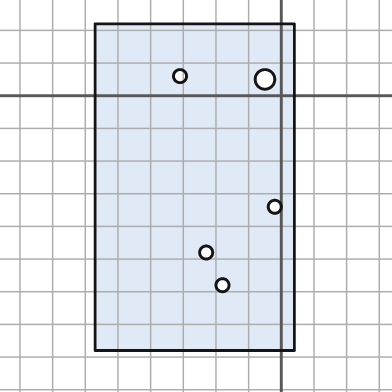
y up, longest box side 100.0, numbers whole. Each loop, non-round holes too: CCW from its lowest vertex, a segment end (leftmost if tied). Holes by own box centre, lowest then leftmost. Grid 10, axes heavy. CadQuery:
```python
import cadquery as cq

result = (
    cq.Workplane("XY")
    .moveTo(-57.0, -78.0)
    .lineTo(4.0, -78.0)
    .lineTo(4.0, 22.0)
    .lineTo(-57.0, 22.0)
    .close()
    .moveTo(-18.0, -58.0)
    .circle(2.0)
    .moveTo(-23.0, -48.0)
    .circle(2.0)
    .moveTo(-2.0, -34.0)
    .circle(2.0)
    .moveTo(-5.0, 5.0)
    .circle(3.0)
    .moveTo(-31.0, 6.0)
    .circle(2.0)
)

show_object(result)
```